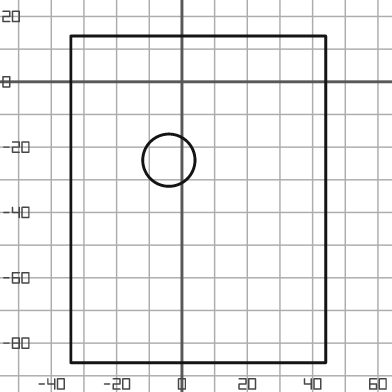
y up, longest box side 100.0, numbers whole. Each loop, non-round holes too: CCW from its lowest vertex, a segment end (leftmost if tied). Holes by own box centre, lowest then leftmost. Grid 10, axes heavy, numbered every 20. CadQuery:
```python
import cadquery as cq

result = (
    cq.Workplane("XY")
    .moveTo(-34.0, -86.0)
    .lineTo(44.0, -86.0)
    .lineTo(44.0, 14.0)
    .lineTo(-34.0, 14.0)
    .close()
    .moveTo(-4.0, -24.0)
    .circle(8.0)
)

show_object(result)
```